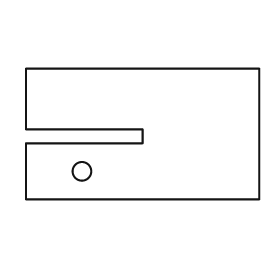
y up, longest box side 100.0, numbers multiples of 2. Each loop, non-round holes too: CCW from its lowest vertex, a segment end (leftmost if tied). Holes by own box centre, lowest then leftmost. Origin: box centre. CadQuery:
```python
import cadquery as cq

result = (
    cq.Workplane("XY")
    .moveTo(-50.0, -28.0)
    .lineTo(50.0, -28.0)
    .lineTo(50.0, 28.0)
    .lineTo(-50.0, 28.0)
    .lineTo(-50.0, 2.0)
    .lineTo(0.0, 2.0)
    .lineTo(0.0, -4.0)
    .lineTo(-50.0, -4.0)
    .close()
    .moveTo(-26.0, -16.0)
    .circle(4.0)
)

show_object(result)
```